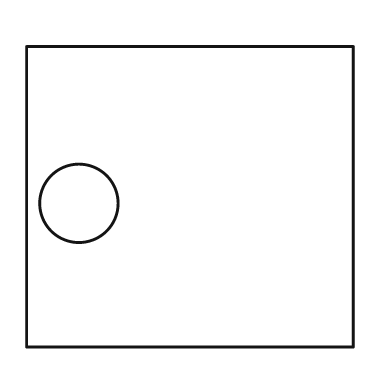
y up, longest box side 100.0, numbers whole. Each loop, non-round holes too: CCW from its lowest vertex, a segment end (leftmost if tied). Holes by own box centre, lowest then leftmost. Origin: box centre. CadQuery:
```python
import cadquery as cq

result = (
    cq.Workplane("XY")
    .moveTo(-50.0, -46.0)
    .lineTo(50.0, -46.0)
    .lineTo(50.0, 46.0)
    .lineTo(-50.0, 46.0)
    .close()
    .moveTo(-34.0, -2.0)
    .circle(12.0)
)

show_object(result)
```